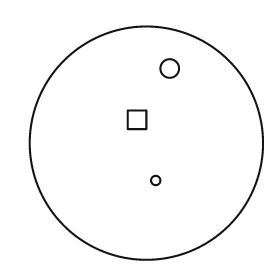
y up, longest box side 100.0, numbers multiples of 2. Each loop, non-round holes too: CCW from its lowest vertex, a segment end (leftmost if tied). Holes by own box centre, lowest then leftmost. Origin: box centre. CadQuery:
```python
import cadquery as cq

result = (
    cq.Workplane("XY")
    .moveTo(0.0, 0.0)
    .circle(50.0)
    .moveTo(4.0, -16.0)
    .circle(2.0)
    .moveTo(-8.0, 6.0)
    .lineTo(0.0, 6.0)
    .lineTo(0.0, 14.0)
    .lineTo(-8.0, 14.0)
    .close()
    .moveTo(10.0, 32.0)
    .circle(4.0)
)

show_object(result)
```